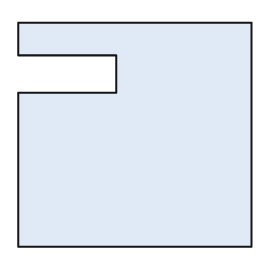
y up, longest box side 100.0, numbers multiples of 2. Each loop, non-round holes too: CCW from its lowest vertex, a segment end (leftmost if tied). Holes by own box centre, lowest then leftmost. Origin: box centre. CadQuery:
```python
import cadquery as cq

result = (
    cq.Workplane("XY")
    .moveTo(-50.0, -48.0)
    .lineTo(50.0, -48.0)
    .lineTo(50.0, 48.0)
    .lineTo(-50.0, 48.0)
    .lineTo(-50.0, 34.0)
    .lineTo(-8.0, 34.0)
    .lineTo(-8.0, 18.0)
    .lineTo(-50.0, 18.0)
    .close()
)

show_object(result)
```